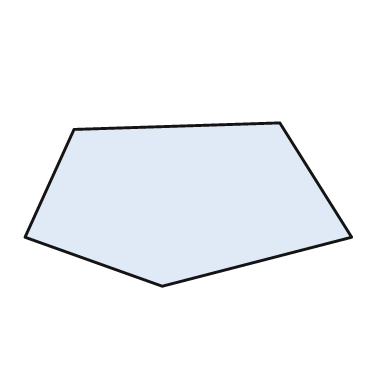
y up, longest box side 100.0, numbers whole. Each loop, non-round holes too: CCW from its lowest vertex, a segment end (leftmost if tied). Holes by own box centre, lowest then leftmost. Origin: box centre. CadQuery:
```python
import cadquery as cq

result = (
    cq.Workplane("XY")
    .moveTo(-8.0, -25.0)
    .lineTo(50.0, -10.0)
    .lineTo(28.0, 25.0)
    .lineTo(-35.0, 23.0)
    .lineTo(-50.0, -10.0)
    .close()
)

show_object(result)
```